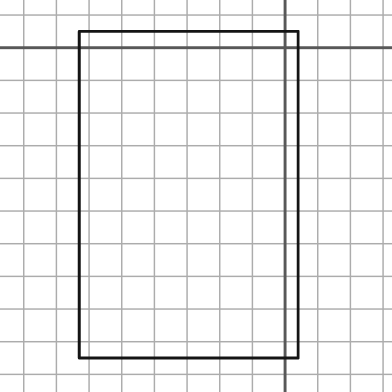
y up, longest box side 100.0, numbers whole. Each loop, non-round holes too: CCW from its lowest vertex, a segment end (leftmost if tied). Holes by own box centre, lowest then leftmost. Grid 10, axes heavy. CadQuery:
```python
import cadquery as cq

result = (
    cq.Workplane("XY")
    .moveTo(-63.0, -95.0)
    .lineTo(4.0, -95.0)
    .lineTo(4.0, 5.0)
    .lineTo(-63.0, 5.0)
    .close()
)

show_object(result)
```